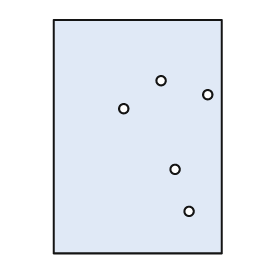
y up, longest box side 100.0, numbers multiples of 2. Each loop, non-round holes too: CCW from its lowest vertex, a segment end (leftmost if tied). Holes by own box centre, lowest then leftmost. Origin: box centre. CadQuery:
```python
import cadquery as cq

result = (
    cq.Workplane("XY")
    .moveTo(-36.0, -50.0)
    .lineTo(36.0, -50.0)
    .lineTo(36.0, 50.0)
    .lineTo(-36.0, 50.0)
    .close()
    .moveTo(22.0, -32.0)
    .circle(2.0)
    .moveTo(16.0, -14.0)
    .circle(2.0)
    .moveTo(-6.0, 12.0)
    .circle(2.0)
    .moveTo(30.0, 18.0)
    .circle(2.0)
    .moveTo(10.0, 24.0)
    .circle(2.0)
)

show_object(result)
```